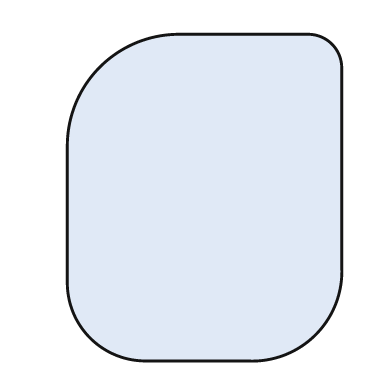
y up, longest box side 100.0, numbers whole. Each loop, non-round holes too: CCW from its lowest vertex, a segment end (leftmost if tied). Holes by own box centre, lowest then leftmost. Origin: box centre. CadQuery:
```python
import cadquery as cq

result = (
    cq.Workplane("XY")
    .moveTo(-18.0, -50.0)
    .lineTo(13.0, -50.0)
    .threePointArc((34.0, -42.0), (42.0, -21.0))
    .lineTo(42.0, 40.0)
    .threePointArc((39.0, 47.0), (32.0, 50.0))
    .lineTo(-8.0, 50.0)
    .threePointArc((-32.0, 40.0), (-42.0, 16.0))
    .lineTo(-42.0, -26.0)
    .threePointArc((-35.0, -43.0), (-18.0, -50.0))
    .close()
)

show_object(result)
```